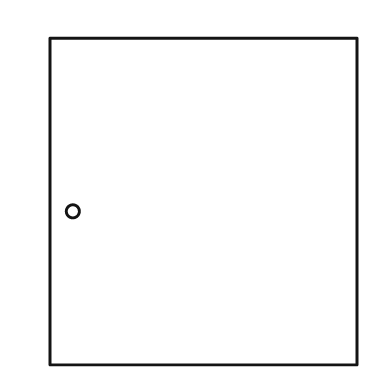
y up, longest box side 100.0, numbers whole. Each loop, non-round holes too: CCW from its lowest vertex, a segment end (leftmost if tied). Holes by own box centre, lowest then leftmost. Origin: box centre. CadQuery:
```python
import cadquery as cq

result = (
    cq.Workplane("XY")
    .moveTo(-47.0, -50.0)
    .lineTo(47.0, -50.0)
    .lineTo(47.0, 50.0)
    .lineTo(-47.0, 50.0)
    .close()
    .moveTo(-40.0, -3.0)
    .circle(2.0)
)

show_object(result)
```